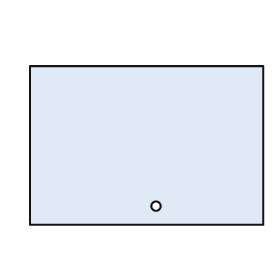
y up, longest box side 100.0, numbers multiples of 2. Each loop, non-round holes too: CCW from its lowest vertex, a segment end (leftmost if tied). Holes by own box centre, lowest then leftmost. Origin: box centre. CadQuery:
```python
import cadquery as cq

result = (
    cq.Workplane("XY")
    .moveTo(-50.0, -34.0)
    .lineTo(50.0, -34.0)
    .lineTo(50.0, 34.0)
    .lineTo(-50.0, 34.0)
    .close()
    .moveTo(4.0, -26.0)
    .circle(2.0)
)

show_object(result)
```